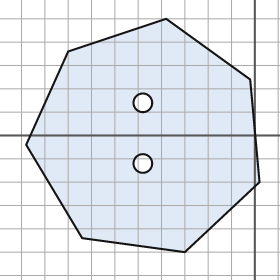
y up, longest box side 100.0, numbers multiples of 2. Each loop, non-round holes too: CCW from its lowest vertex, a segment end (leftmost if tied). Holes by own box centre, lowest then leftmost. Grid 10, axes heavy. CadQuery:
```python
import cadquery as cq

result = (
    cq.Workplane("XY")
    .moveTo(-30.0, -50.0)
    .lineTo(2.0, -20.0)
    .lineTo(-2.0, 24.0)
    .lineTo(-38.0, 50.0)
    .lineTo(-80.0, 36.0)
    .lineTo(-98.0, -4.0)
    .lineTo(-74.0, -44.0)
    .close()
    .moveTo(-48.0, -12.0)
    .circle(4.0)
    .moveTo(-48.0, 14.0)
    .circle(4.0)
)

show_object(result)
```